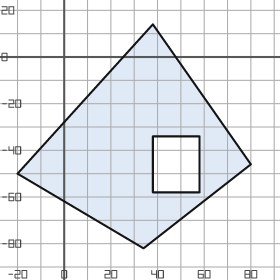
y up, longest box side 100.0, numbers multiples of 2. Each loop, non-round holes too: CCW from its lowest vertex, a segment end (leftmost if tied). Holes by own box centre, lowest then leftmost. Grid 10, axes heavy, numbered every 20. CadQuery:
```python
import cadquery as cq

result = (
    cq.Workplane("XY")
    .moveTo(34.0, -82.0)
    .lineTo(80.0, -46.0)
    .lineTo(38.0, 14.0)
    .lineTo(-20.0, -50.0)
    .close()
    .moveTo(38.0, -58.0)
    .lineTo(58.0, -58.0)
    .lineTo(58.0, -34.0)
    .lineTo(38.0, -34.0)
    .close()
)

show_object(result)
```